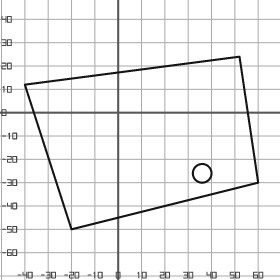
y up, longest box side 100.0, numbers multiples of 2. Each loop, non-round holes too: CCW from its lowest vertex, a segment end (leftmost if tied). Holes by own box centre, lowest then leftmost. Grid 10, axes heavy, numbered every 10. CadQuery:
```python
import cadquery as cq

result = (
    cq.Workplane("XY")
    .moveTo(-20.0, -50.0)
    .lineTo(60.0, -30.0)
    .lineTo(52.0, 24.0)
    .lineTo(-40.0, 12.0)
    .close()
    .moveTo(36.0, -26.0)
    .circle(4.0)
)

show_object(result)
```